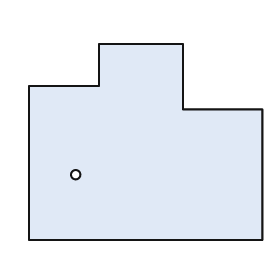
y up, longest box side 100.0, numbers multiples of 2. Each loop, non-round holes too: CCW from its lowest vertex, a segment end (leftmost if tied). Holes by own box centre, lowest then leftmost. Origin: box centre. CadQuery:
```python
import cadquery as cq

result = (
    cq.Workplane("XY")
    .moveTo(-50.0, -42.0)
    .lineTo(50.0, -42.0)
    .lineTo(50.0, 14.0)
    .lineTo(16.0, 14.0)
    .lineTo(16.0, 42.0)
    .lineTo(-20.0, 42.0)
    .lineTo(-20.0, 24.0)
    .lineTo(-50.0, 24.0)
    .close()
    .moveTo(-30.0, -14.0)
    .circle(2.0)
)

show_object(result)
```